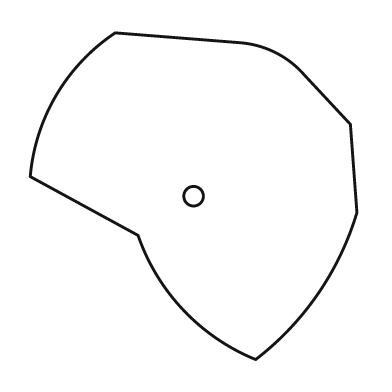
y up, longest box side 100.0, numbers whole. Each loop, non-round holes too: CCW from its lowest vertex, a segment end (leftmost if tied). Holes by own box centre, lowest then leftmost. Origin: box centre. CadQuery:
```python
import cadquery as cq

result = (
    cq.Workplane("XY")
    .moveTo(19.0, -50.0)
    .threePointArc((38.0, -30.0), (50.0, -5.0))
    .lineTo(48.0, 22.0)
    .lineTo(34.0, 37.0)
    .threePointArc((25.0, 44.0), (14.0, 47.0))
    .lineTo(-24.0, 50.0)
    .threePointArc((-42.0, 31.0), (-50.0, 6.0))
    .lineTo(-17.0, -12.0)
    .threePointArc((-3.0, -35.0), (19.0, -50.0))
    .close()
    .moveTo(0.0, 0.0)
    .circle(3.0)
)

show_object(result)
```